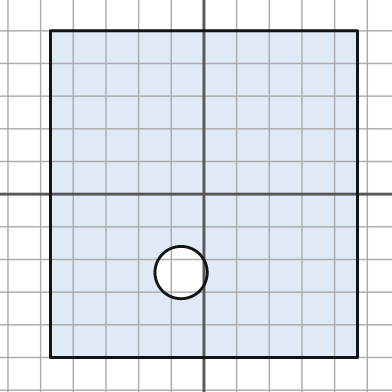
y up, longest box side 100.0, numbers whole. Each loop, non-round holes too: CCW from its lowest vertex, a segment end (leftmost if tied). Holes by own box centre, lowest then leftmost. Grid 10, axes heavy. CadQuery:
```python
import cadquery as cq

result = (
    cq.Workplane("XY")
    .moveTo(-47.0, -50.0)
    .lineTo(47.0, -50.0)
    .lineTo(47.0, 50.0)
    .lineTo(-47.0, 50.0)
    .close()
    .moveTo(-7.0, -24.0)
    .circle(8.0)
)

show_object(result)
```